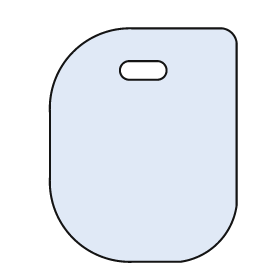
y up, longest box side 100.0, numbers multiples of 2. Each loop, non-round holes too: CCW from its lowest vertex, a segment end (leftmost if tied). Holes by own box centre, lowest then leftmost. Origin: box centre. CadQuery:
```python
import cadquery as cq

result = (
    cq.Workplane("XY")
    .moveTo(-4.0, -50.0)
    .lineTo(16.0, -50.0)
    .threePointArc((32.0, -42.0), (40.0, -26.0))
    .lineTo(40.0, 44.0)
    .threePointArc((38.0, 48.0), (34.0, 50.0))
    .lineTo(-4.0, 50.0)
    .threePointArc((-30.0, 40.0), (-40.0, 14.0))
    .lineTo(-40.0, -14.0)
    .threePointArc((-30.0, -40.0), (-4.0, -50.0))
    .close()
    .moveTo(-6.0, 28.0)
    .lineTo(6.0, 28.0)
    .threePointArc((10.0, 32.0), (6.0, 36.0))
    .lineTo(-6.0, 36.0)
    .threePointArc((-10.0, 32.0), (-6.0, 28.0))
    .close()
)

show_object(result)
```